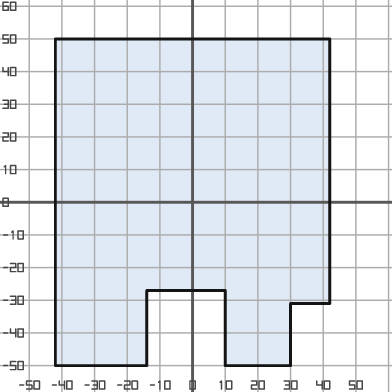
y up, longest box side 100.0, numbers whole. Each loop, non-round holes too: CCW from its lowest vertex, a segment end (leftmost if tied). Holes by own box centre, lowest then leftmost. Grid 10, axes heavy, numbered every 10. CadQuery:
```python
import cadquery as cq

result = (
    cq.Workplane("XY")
    .moveTo(-42.0, -50.0)
    .lineTo(-14.0, -50.0)
    .lineTo(-14.0, -27.0)
    .lineTo(10.0, -27.0)
    .lineTo(10.0, -50.0)
    .lineTo(30.0, -50.0)
    .lineTo(30.0, -31.0)
    .lineTo(42.0, -31.0)
    .lineTo(42.0, 50.0)
    .lineTo(-42.0, 50.0)
    .close()
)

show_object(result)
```